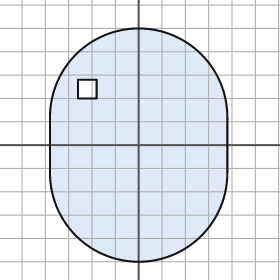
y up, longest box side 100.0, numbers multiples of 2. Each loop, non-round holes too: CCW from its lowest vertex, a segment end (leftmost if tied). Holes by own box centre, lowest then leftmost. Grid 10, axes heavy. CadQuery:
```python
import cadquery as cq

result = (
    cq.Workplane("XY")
    .moveTo(-38.0, -12.0)
    .threePointArc((0.0, -50.0), (38.0, -12.0))
    .lineTo(38.0, 12.0)
    .threePointArc((0.0, 50.0), (-38.0, 12.0))
    .close()
    .moveTo(-26.0, 20.0)
    .lineTo(-18.0, 20.0)
    .lineTo(-18.0, 28.0)
    .lineTo(-26.0, 28.0)
    .close()
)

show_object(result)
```